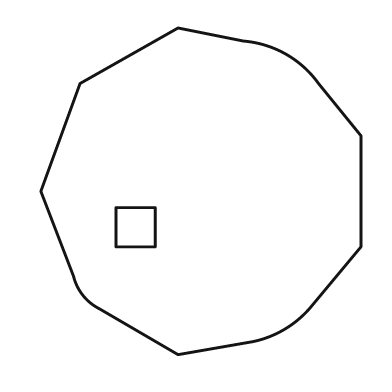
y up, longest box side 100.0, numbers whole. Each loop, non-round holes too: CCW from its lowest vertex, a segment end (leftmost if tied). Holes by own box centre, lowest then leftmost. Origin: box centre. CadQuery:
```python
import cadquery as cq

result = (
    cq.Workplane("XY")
    .moveTo(-7.0, -50.0)
    .lineTo(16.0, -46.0)
    .threePointArc((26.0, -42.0), (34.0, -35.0))
    .lineTo(49.0, -17.0)
    .lineTo(49.0, 17.0)
    .lineTo(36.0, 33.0)
    .threePointArc((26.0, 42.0), (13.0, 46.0))
    .lineTo(-7.0, 50.0)
    .lineTo(-37.0, 33.0)
    .lineTo(-49.0, 0.0)
    .lineTo(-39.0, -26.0)
    .threePointArc((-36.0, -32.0), (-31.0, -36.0))
    .close()
    .moveTo(-26.0, -17.0)
    .lineTo(-14.0, -17.0)
    .lineTo(-14.0, -5.0)
    .lineTo(-26.0, -5.0)
    .close()
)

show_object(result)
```